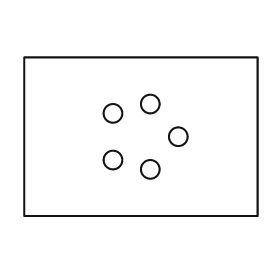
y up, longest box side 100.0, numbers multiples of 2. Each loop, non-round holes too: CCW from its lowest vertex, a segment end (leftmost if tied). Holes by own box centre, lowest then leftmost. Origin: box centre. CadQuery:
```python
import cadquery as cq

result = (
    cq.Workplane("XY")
    .moveTo(-50.0, -34.0)
    .lineTo(50.0, -34.0)
    .lineTo(50.0, 34.0)
    .lineTo(-50.0, 34.0)
    .close()
    .moveTo(4.0, -14.0)
    .circle(4.0)
    .moveTo(-12.0, -10.0)
    .circle(4.0)
    .moveTo(16.0, 0.0)
    .circle(4.0)
    .moveTo(-12.0, 10.0)
    .circle(4.0)
    .moveTo(4.0, 14.0)
    .circle(4.0)
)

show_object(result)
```